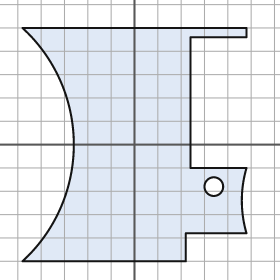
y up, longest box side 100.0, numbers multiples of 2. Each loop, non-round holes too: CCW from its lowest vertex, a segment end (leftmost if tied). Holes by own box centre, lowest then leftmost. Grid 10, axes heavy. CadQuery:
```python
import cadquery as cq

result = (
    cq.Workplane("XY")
    .moveTo(-48.0, -50.0)
    .lineTo(22.0, -50.0)
    .lineTo(22.0, -38.0)
    .lineTo(48.0, -38.0)
    .threePointArc((46.0, -24.0), (48.0, -10.0))
    .lineTo(24.0, -10.0)
    .lineTo(24.0, 46.0)
    .lineTo(48.0, 46.0)
    .lineTo(48.0, 50.0)
    .lineTo(-48.0, 50.0)
    .threePointArc((-26.0, 0.0), (-48.0, -50.0))
    .close()
    .moveTo(34.0, -18.0)
    .circle(4.0)
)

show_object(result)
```